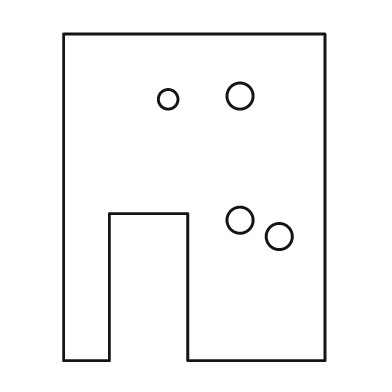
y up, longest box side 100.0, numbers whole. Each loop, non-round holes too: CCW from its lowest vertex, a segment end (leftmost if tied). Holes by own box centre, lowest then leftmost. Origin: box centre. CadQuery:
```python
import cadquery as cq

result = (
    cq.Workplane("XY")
    .moveTo(-40.0, -50.0)
    .lineTo(-26.0, -50.0)
    .lineTo(-26.0, -5.0)
    .lineTo(-2.0, -5.0)
    .lineTo(-2.0, -50.0)
    .lineTo(40.0, -50.0)
    .lineTo(40.0, 50.0)
    .lineTo(-40.0, 50.0)
    .close()
    .moveTo(26.0, -12.0)
    .circle(4.0)
    .moveTo(14.0, -7.0)
    .circle(4.0)
    .moveTo(-8.0, 30.0)
    .circle(3.0)
    .moveTo(14.0, 31.0)
    .circle(4.0)
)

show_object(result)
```